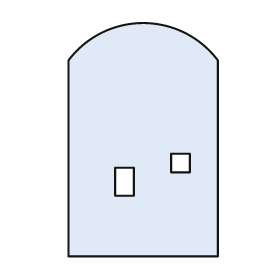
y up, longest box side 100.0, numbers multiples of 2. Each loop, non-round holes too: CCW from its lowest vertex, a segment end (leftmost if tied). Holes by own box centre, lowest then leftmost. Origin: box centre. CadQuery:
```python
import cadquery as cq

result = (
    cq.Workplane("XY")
    .moveTo(-32.0, -50.0)
    .lineTo(32.0, -50.0)
    .lineTo(32.0, 34.0)
    .threePointArc((0.0, 50.0), (-32.0, 34.0))
    .close()
    .moveTo(-12.0, -24.0)
    .lineTo(-4.0, -24.0)
    .lineTo(-4.0, -12.0)
    .lineTo(-12.0, -12.0)
    .close()
    .moveTo(12.0, -14.0)
    .lineTo(20.0, -14.0)
    .lineTo(20.0, -6.0)
    .lineTo(12.0, -6.0)
    .close()
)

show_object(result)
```